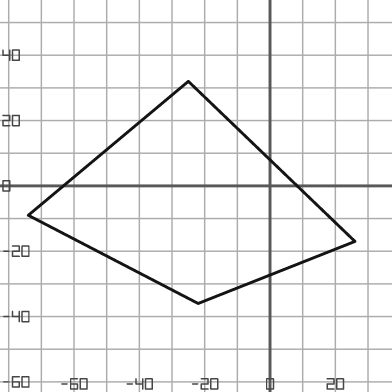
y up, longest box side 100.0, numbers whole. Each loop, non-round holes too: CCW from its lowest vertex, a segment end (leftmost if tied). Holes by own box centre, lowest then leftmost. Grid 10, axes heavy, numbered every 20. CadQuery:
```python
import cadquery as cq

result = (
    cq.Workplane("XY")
    .moveTo(-22.0, -36.0)
    .lineTo(26.0, -17.0)
    .lineTo(-25.0, 32.0)
    .lineTo(-74.0, -9.0)
    .close()
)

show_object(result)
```